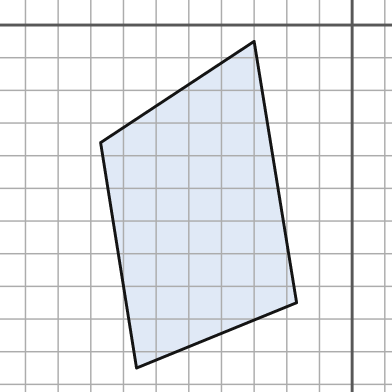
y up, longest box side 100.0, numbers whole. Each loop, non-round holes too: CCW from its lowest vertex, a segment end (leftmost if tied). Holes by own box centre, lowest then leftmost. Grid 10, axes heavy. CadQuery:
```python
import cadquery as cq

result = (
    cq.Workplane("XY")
    .moveTo(-66.0, -105.0)
    .lineTo(-17.0, -85.0)
    .lineTo(-30.0, -5.0)
    .lineTo(-77.0, -36.0)
    .close()
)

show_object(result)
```